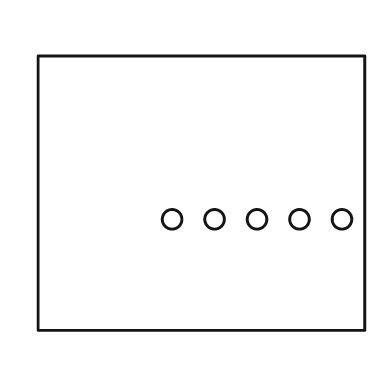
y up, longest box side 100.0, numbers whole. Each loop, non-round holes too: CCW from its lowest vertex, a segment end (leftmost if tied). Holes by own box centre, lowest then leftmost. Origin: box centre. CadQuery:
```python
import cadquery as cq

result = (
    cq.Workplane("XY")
    .moveTo(-50.0, -42.0)
    .lineTo(50.0, -42.0)
    .lineTo(50.0, 42.0)
    .lineTo(-50.0, 42.0)
    .close()
    .moveTo(-9.0, -8.0)
    .circle(3.0)
    .moveTo(4.0, -8.0)
    .circle(3.0)
    .moveTo(17.0, -8.0)
    .circle(3.0)
    .moveTo(30.0, -8.0)
    .circle(3.0)
    .moveTo(43.0, -8.0)
    .circle(3.0)
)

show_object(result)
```